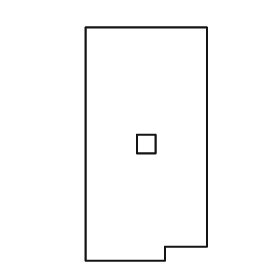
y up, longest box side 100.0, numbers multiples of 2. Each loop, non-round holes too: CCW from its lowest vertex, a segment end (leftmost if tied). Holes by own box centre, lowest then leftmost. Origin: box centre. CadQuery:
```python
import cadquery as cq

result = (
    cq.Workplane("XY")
    .moveTo(-26.0, -50.0)
    .lineTo(8.0, -50.0)
    .lineTo(8.0, -44.0)
    .lineTo(26.0, -44.0)
    .lineTo(26.0, 50.0)
    .lineTo(-26.0, 50.0)
    .close()
    .moveTo(-4.0, -4.0)
    .lineTo(4.0, -4.0)
    .lineTo(4.0, 4.0)
    .lineTo(-4.0, 4.0)
    .close()
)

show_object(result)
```